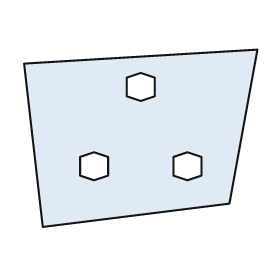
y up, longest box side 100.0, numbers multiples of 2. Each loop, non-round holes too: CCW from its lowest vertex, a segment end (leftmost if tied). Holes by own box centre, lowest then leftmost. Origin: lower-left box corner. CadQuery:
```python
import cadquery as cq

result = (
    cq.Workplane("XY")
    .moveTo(8.0, 0.0)
    .lineTo(88.0, 10.0)
    .lineTo(100.0, 76.0)
    .lineTo(0.0, 70.0)
    .close()
    .moveTo(30.0, 20.0)
    .lineTo(36.0, 22.0)
    .lineTo(36.0, 30.0)
    .lineTo(30.0, 32.0)
    .lineTo(24.0, 30.0)
    .lineTo(24.0, 22.0)
    .close()
    .moveTo(70.0, 20.0)
    .lineTo(76.0, 22.0)
    .lineTo(76.0, 30.0)
    .lineTo(70.0, 32.0)
    .lineTo(64.0, 30.0)
    .lineTo(64.0, 22.0)
    .close()
    .moveTo(50.0, 54.0)
    .lineTo(56.0, 56.0)
    .lineTo(56.0, 64.0)
    .lineTo(50.0, 66.0)
    .lineTo(44.0, 64.0)
    .lineTo(44.0, 56.0)
    .close()
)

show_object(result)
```